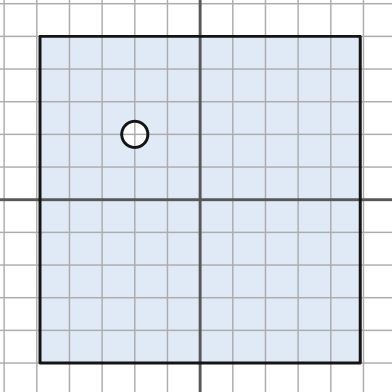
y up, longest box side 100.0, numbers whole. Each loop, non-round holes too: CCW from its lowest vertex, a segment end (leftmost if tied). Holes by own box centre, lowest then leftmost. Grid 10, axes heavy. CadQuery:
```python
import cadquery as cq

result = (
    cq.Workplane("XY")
    .moveTo(-49.0, -50.0)
    .lineTo(49.0, -50.0)
    .lineTo(49.0, 50.0)
    .lineTo(-49.0, 50.0)
    .close()
    .moveTo(-20.0, 20.0)
    .circle(4.0)
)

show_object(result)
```